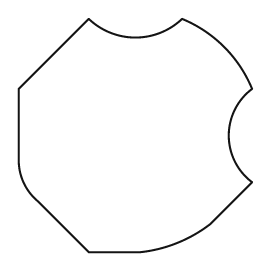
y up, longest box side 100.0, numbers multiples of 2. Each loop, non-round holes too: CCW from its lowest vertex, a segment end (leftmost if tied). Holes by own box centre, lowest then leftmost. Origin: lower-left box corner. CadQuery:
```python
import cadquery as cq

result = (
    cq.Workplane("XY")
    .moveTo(30.0, 0.0)
    .lineTo(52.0, 0.0)
    .threePointArc((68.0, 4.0), (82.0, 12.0))
    .lineTo(100.0, 30.0)
    .threePointArc((90.0, 50.0), (100.0, 70.0))
    .threePointArc((88.0, 88.0), (70.0, 100.0))
    .threePointArc((50.0, 92.0), (30.0, 100.0))
    .lineTo(0.0, 70.0)
    .lineTo(0.0, 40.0)
    .threePointArc((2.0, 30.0), (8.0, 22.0))
    .close()
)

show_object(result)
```